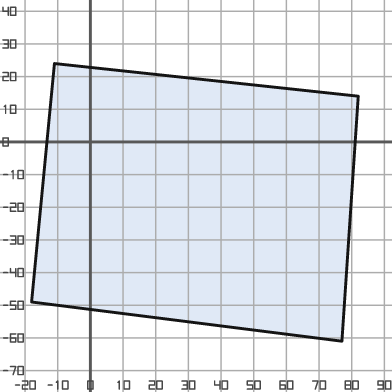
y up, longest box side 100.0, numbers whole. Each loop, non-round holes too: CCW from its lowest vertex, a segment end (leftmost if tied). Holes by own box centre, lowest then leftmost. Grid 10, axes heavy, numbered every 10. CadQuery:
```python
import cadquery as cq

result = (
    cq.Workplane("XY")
    .moveTo(77.0, -61.0)
    .lineTo(82.0, 14.0)
    .lineTo(-11.0, 24.0)
    .lineTo(-18.0, -49.0)
    .close()
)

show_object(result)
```